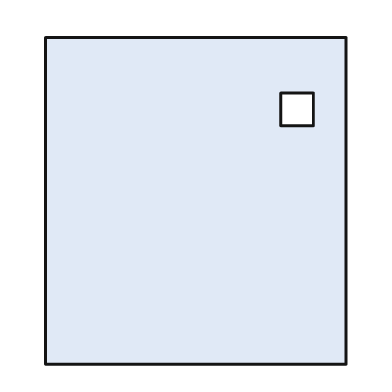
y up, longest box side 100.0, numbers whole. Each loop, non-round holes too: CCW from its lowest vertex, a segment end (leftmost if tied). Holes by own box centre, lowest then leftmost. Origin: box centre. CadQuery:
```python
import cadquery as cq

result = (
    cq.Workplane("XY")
    .moveTo(-46.0, -50.0)
    .lineTo(46.0, -50.0)
    .lineTo(46.0, 50.0)
    .lineTo(-46.0, 50.0)
    .close()
    .moveTo(26.0, 23.0)
    .lineTo(36.0, 23.0)
    .lineTo(36.0, 33.0)
    .lineTo(26.0, 33.0)
    .close()
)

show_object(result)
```